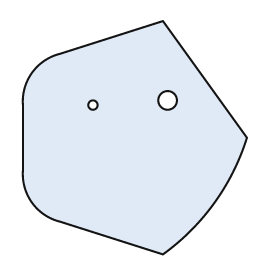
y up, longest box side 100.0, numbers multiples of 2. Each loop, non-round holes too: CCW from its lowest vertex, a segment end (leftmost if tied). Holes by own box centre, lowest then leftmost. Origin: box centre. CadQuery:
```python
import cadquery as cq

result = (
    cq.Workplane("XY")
    .moveTo(12.0, -50.0)
    .threePointArc((34.0, -28.0), (48.0, 0.0))
    .lineTo(12.0, 50.0)
    .lineTo(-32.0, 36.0)
    .threePointArc((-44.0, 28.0), (-48.0, 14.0))
    .lineTo(-48.0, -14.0)
    .threePointArc((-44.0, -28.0), (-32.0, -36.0))
    .close()
    .moveTo(-18.0, 14.0)
    .circle(2.0)
    .moveTo(14.0, 16.0)
    .circle(4.0)
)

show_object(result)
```